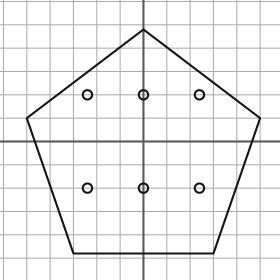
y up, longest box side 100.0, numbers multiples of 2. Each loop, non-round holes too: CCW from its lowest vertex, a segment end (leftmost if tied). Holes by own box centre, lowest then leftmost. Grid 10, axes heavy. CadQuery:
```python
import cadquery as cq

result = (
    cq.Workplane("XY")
    .moveTo(-30.0, -48.0)
    .lineTo(30.0, -48.0)
    .lineTo(50.0, 10.0)
    .lineTo(0.0, 48.0)
    .lineTo(-50.0, 10.0)
    .close()
    .moveTo(-24.0, -20.0)
    .circle(2.0)
    .moveTo(0.0, -20.0)
    .circle(2.0)
    .moveTo(24.0, -20.0)
    .circle(2.0)
    .moveTo(-24.0, 20.0)
    .circle(2.0)
    .moveTo(0.0, 20.0)
    .circle(2.0)
    .moveTo(24.0, 20.0)
    .circle(2.0)
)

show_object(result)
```